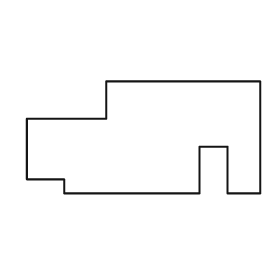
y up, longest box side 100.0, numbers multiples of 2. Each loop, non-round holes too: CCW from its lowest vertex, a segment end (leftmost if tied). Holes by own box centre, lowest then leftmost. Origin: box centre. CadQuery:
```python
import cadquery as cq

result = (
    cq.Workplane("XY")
    .moveTo(-34.0, -24.0)
    .lineTo(24.0, -24.0)
    .lineTo(24.0, -4.0)
    .lineTo(36.0, -4.0)
    .lineTo(36.0, -24.0)
    .lineTo(50.0, -24.0)
    .lineTo(50.0, 24.0)
    .lineTo(-16.0, 24.0)
    .lineTo(-16.0, 8.0)
    .lineTo(-50.0, 8.0)
    .lineTo(-50.0, -18.0)
    .lineTo(-34.0, -18.0)
    .close()
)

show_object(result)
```